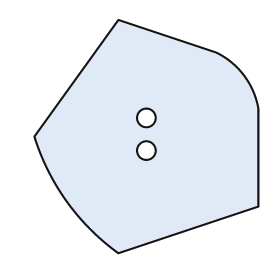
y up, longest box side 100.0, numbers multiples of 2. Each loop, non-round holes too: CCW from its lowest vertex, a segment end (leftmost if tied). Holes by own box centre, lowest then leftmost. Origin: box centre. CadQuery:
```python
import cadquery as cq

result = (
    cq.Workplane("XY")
    .moveTo(-12.0, -50.0)
    .lineTo(48.0, -30.0)
    .lineTo(48.0, 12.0)
    .threePointArc((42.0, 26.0), (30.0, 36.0))
    .lineTo(-12.0, 50.0)
    .lineTo(-48.0, 0.0)
    .threePointArc((-34.0, -28.0), (-12.0, -50.0))
    .close()
    .moveTo(0.0, -6.0)
    .circle(4.0)
    .moveTo(0.0, 8.0)
    .circle(4.0)
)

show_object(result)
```